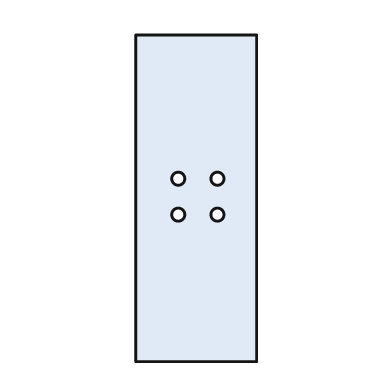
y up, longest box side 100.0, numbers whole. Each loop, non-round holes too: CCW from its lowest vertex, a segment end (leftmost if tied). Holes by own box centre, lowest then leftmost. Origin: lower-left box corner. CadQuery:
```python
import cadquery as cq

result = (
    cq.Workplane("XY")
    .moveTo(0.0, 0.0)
    .lineTo(37.0, 0.0)
    .lineTo(37.0, 100.0)
    .lineTo(0.0, 100.0)
    .close()
    .moveTo(13.0, 45.0)
    .circle(2.0)
    .moveTo(25.0, 45.0)
    .circle(2.0)
    .moveTo(13.0, 56.0)
    .circle(2.0)
    .moveTo(25.0, 56.0)
    .circle(2.0)
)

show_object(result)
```